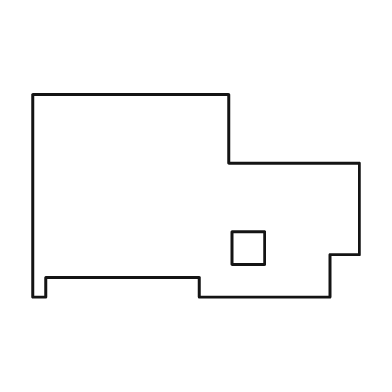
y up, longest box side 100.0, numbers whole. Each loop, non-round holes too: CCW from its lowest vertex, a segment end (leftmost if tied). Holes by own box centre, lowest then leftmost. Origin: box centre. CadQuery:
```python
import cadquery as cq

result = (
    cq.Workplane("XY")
    .moveTo(-50.0, -31.0)
    .lineTo(-46.0, -31.0)
    .lineTo(-46.0, -25.0)
    .lineTo(1.0, -25.0)
    .lineTo(1.0, -31.0)
    .lineTo(41.0, -31.0)
    .lineTo(41.0, -18.0)
    .lineTo(50.0, -18.0)
    .lineTo(50.0, 10.0)
    .lineTo(10.0, 10.0)
    .lineTo(10.0, 31.0)
    .lineTo(-50.0, 31.0)
    .close()
    .moveTo(11.0, -21.0)
    .lineTo(21.0, -21.0)
    .lineTo(21.0, -11.0)
    .lineTo(11.0, -11.0)
    .close()
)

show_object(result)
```